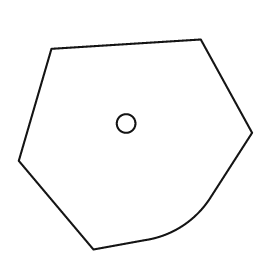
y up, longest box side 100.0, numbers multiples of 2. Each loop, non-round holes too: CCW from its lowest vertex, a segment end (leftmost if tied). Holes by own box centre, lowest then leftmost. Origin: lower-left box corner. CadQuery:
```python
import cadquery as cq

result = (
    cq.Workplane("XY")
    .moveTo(32.0, 0.0)
    .lineTo(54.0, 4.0)
    .threePointArc((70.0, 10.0), (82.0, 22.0))
    .lineTo(100.0, 50.0)
    .lineTo(78.0, 90.0)
    .lineTo(14.0, 86.0)
    .lineTo(0.0, 38.0)
    .close()
    .moveTo(46.0, 54.0)
    .circle(4.0)
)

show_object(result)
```